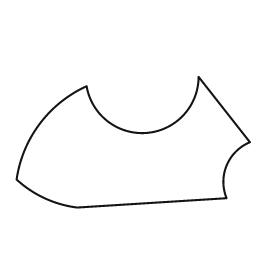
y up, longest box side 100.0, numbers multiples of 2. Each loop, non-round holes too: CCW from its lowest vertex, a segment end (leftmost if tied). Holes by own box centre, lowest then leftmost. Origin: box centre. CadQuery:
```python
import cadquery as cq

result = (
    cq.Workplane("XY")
    .moveTo(-24.0, -28.0)
    .lineTo(40.0, -24.0)
    .threePointArc((40.0, -10.0), (50.0, 0.0))
    .lineTo(28.0, 28.0)
    .threePointArc((6.0, 4.0), (-20.0, 24.0))
    .threePointArc((-40.0, 8.0), (-50.0, -16.0))
    .threePointArc((-38.0, -24.0), (-24.0, -28.0))
    .close()
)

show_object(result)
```